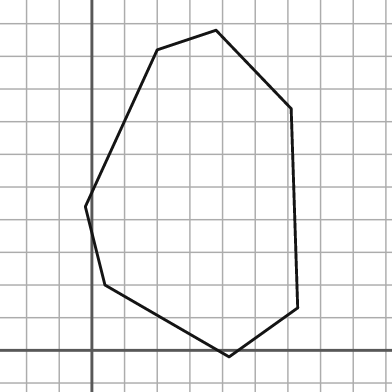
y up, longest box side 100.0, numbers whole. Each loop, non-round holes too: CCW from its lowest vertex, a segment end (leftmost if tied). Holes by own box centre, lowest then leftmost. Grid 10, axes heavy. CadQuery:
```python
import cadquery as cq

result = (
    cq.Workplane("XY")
    .moveTo(42.0, -2.0)
    .lineTo(63.0, 13.0)
    .lineTo(61.0, 74.0)
    .lineTo(38.0, 98.0)
    .lineTo(20.0, 92.0)
    .lineTo(-2.0, 44.0)
    .lineTo(4.0, 20.0)
    .close()
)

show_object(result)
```